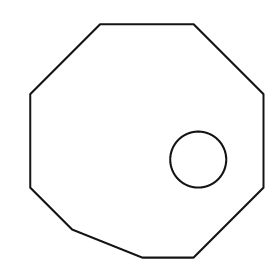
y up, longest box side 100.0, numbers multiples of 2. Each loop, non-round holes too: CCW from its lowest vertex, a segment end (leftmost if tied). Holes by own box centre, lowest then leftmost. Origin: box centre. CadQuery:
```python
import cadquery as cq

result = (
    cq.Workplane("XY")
    .moveTo(-2.0, -50.0)
    .lineTo(20.0, -50.0)
    .lineTo(50.0, -20.0)
    .lineTo(50.0, 20.0)
    .lineTo(20.0, 50.0)
    .lineTo(-20.0, 50.0)
    .lineTo(-50.0, 20.0)
    .lineTo(-50.0, -20.0)
    .lineTo(-32.0, -38.0)
    .close()
    .moveTo(22.0, -8.0)
    .circle(12.0)
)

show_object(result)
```